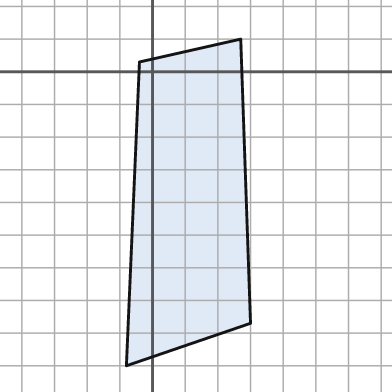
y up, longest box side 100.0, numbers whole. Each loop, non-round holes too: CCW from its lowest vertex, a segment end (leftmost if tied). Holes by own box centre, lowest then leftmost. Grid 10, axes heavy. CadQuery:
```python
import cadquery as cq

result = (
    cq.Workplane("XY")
    .moveTo(-8.0, -90.0)
    .lineTo(30.0, -77.0)
    .lineTo(27.0, 10.0)
    .lineTo(-4.0, 3.0)
    .close()
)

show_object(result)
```